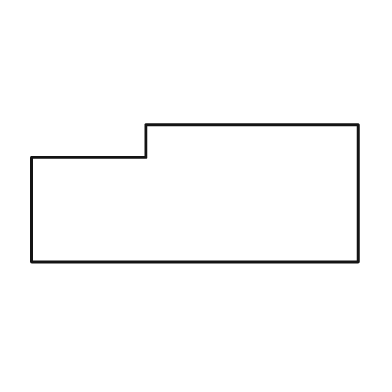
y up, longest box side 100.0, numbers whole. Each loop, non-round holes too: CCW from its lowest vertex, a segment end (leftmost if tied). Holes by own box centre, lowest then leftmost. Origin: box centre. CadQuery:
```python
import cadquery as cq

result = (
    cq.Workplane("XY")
    .moveTo(-50.0, -21.0)
    .lineTo(50.0, -21.0)
    .lineTo(50.0, 21.0)
    .lineTo(-15.0, 21.0)
    .lineTo(-15.0, 11.0)
    .lineTo(-50.0, 11.0)
    .close()
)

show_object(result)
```